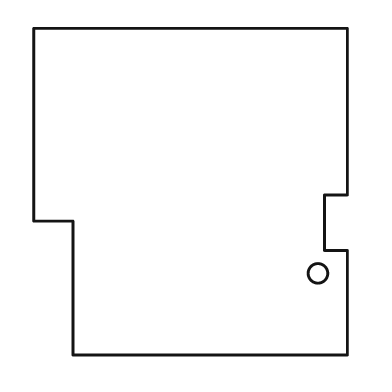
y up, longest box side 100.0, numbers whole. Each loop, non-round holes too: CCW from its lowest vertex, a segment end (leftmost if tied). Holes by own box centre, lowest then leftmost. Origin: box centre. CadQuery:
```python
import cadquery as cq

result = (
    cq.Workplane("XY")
    .moveTo(-36.0, -50.0)
    .lineTo(48.0, -50.0)
    .lineTo(48.0, -18.0)
    .lineTo(41.0, -18.0)
    .lineTo(41.0, -1.0)
    .lineTo(48.0, -1.0)
    .lineTo(48.0, 50.0)
    .lineTo(-48.0, 50.0)
    .lineTo(-48.0, -9.0)
    .lineTo(-36.0, -9.0)
    .close()
    .moveTo(39.0, -25.0)
    .circle(3.0)
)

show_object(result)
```